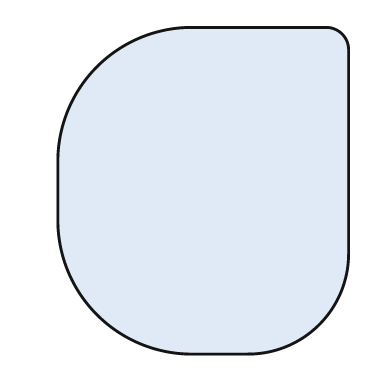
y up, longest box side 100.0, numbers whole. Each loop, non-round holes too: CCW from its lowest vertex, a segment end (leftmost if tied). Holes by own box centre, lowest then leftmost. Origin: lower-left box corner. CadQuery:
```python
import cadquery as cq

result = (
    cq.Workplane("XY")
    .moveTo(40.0, 0.0)
    .lineTo(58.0, 0.0)
    .threePointArc((80.0, 9.0), (89.0, 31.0))
    .lineTo(89.0, 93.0)
    .threePointArc((87.0, 98.0), (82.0, 100.0))
    .lineTo(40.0, 100.0)
    .threePointArc((12.0, 88.0), (0.0, 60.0))
    .lineTo(0.0, 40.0)
    .threePointArc((12.0, 12.0), (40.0, 0.0))
    .close()
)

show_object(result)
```